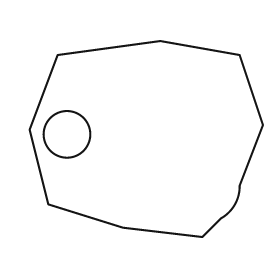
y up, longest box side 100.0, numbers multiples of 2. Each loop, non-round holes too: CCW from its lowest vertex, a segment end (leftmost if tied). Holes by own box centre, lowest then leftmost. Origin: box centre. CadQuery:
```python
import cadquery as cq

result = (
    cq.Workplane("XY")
    .moveTo(24.0, -42.0)
    .lineTo(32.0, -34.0)
    .threePointArc((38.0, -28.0), (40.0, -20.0))
    .lineTo(50.0, 6.0)
    .lineTo(40.0, 36.0)
    .lineTo(6.0, 42.0)
    .lineTo(-38.0, 36.0)
    .lineTo(-50.0, 4.0)
    .lineTo(-42.0, -28.0)
    .lineTo(-10.0, -38.0)
    .close()
    .moveTo(-34.0, 2.0)
    .circle(10.0)
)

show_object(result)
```